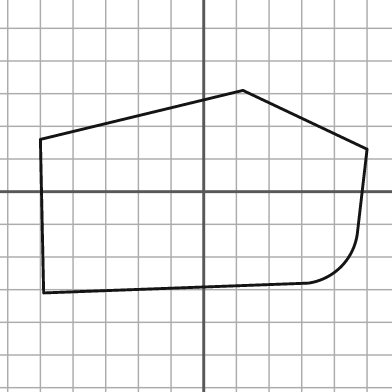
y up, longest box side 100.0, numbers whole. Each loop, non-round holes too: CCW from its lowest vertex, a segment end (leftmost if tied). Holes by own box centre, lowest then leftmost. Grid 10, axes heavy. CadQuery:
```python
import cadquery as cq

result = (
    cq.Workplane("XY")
    .moveTo(-49.0, -31.0)
    .lineTo(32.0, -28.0)
    .threePointArc((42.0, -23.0), (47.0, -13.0))
    .lineTo(50.0, 13.0)
    .lineTo(12.0, 31.0)
    .lineTo(-50.0, 16.0)
    .close()
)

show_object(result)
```